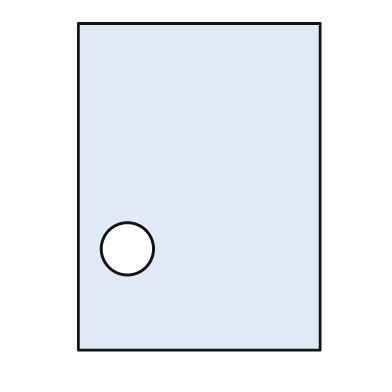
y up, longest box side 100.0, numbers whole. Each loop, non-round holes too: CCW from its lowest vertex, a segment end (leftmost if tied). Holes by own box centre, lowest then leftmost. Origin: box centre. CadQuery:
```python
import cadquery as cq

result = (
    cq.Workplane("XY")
    .moveTo(-37.0, -50.0)
    .lineTo(37.0, -50.0)
    .lineTo(37.0, 50.0)
    .lineTo(-37.0, 50.0)
    .close()
    .moveTo(-22.0, -19.0)
    .circle(8.0)
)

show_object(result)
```